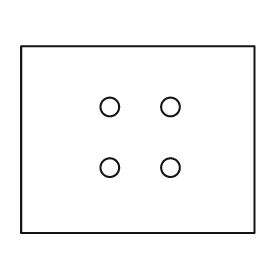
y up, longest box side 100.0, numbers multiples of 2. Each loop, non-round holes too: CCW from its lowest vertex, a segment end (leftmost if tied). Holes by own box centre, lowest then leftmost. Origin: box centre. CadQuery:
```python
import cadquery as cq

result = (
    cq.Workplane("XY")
    .moveTo(-50.0, -40.0)
    .lineTo(50.0, -40.0)
    .lineTo(50.0, 40.0)
    .lineTo(-50.0, 40.0)
    .close()
    .moveTo(-12.0, -12.0)
    .circle(4.0)
    .moveTo(14.0, -12.0)
    .circle(4.0)
    .moveTo(-12.0, 14.0)
    .circle(4.0)
    .moveTo(14.0, 14.0)
    .circle(4.0)
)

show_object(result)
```